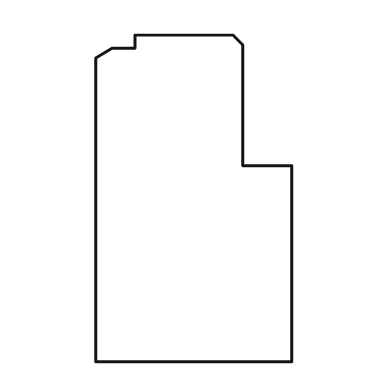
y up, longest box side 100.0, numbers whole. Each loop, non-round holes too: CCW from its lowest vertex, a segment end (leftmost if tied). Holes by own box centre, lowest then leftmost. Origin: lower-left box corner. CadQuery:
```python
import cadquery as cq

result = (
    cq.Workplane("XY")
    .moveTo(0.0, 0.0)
    .lineTo(60.0, 0.0)
    .lineTo(60.0, 60.0)
    .lineTo(45.0, 60.0)
    .lineTo(45.0, 97.0)
    .lineTo(42.0, 100.0)
    .lineTo(12.0, 100.0)
    .lineTo(12.0, 96.0)
    .lineTo(5.0, 96.0)
    .lineTo(0.0, 93.0)
    .close()
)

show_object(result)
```